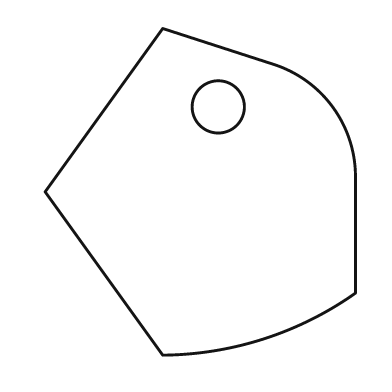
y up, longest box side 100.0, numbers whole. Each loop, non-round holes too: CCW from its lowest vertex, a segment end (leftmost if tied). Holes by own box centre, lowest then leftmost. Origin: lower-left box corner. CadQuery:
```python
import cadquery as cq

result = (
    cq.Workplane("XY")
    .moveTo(36.0, 0.0)
    .threePointArc((67.0, 5.0), (95.0, 19.0))
    .lineTo(95.0, 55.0)
    .threePointArc((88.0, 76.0), (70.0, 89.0))
    .lineTo(36.0, 100.0)
    .lineTo(0.0, 50.0)
    .close()
    .moveTo(53.0, 76.0)
    .circle(8.0)
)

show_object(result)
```